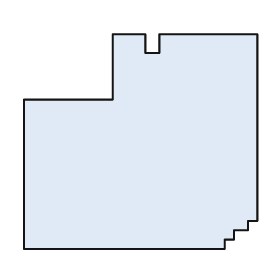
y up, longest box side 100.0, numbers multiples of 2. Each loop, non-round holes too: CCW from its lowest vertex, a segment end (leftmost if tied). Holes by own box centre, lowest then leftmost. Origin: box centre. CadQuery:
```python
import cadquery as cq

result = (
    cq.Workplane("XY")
    .moveTo(-50.0, -46.0)
    .lineTo(36.0, -46.0)
    .lineTo(36.0, -42.0)
    .lineTo(40.0, -42.0)
    .lineTo(40.0, -38.0)
    .lineTo(46.0, -38.0)
    .lineTo(46.0, -34.0)
    .lineTo(50.0, -34.0)
    .lineTo(50.0, 46.0)
    .lineTo(8.0, 46.0)
    .lineTo(8.0, 38.0)
    .lineTo(2.0, 38.0)
    .lineTo(2.0, 46.0)
    .lineTo(-12.0, 46.0)
    .lineTo(-12.0, 18.0)
    .lineTo(-50.0, 18.0)
    .close()
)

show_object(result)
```